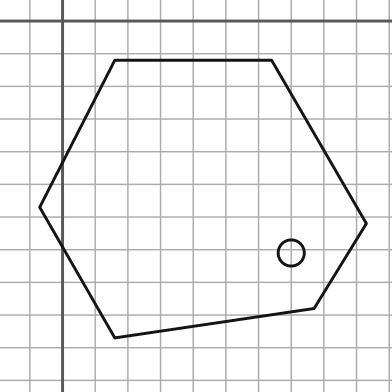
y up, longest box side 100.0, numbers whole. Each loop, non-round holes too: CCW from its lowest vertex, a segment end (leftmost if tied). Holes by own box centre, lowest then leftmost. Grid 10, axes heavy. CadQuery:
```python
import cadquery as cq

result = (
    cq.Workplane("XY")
    .moveTo(16.0, -97.0)
    .lineTo(77.0, -88.0)
    .lineTo(93.0, -62.0)
    .lineTo(64.0, -12.0)
    .lineTo(16.0, -12.0)
    .lineTo(-7.0, -57.0)
    .close()
    .moveTo(70.0, -71.0)
    .circle(4.0)
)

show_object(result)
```